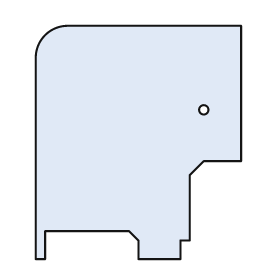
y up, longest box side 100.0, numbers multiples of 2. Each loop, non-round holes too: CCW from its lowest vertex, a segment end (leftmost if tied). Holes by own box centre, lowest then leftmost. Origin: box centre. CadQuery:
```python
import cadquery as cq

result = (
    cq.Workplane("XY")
    .moveTo(-44.0, -50.0)
    .lineTo(-40.0, -50.0)
    .lineTo(-40.0, -38.0)
    .lineTo(-4.0, -38.0)
    .lineTo(0.0, -42.0)
    .lineTo(0.0, -50.0)
    .lineTo(18.0, -50.0)
    .lineTo(18.0, -42.0)
    .lineTo(22.0, -42.0)
    .lineTo(22.0, -14.0)
    .lineTo(28.0, -8.0)
    .lineTo(44.0, -8.0)
    .lineTo(44.0, 50.0)
    .lineTo(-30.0, 50.0)
    .threePointArc((-40.0, 46.0), (-44.0, 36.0))
    .close()
    .moveTo(28.0, 14.0)
    .circle(2.0)
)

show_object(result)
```